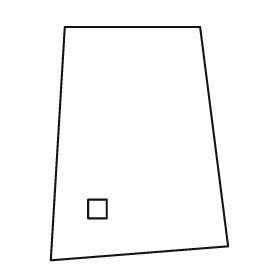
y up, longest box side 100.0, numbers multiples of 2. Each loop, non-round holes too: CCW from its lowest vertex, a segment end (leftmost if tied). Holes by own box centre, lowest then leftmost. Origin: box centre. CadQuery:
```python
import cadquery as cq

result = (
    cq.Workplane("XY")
    .moveTo(-38.0, -50.0)
    .lineTo(38.0, -44.0)
    .lineTo(26.0, 50.0)
    .lineTo(-32.0, 50.0)
    .close()
    .moveTo(-22.0, -32.0)
    .lineTo(-14.0, -32.0)
    .lineTo(-14.0, -24.0)
    .lineTo(-22.0, -24.0)
    .close()
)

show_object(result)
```